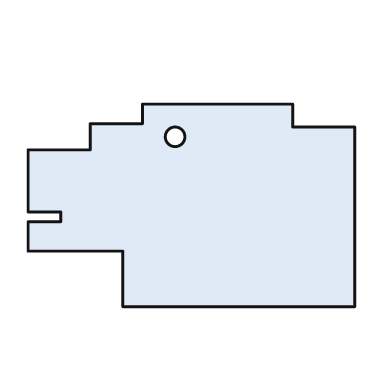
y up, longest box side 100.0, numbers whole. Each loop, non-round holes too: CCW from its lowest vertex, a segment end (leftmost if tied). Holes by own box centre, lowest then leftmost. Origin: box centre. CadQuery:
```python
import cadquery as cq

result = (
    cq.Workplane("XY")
    .moveTo(-21.0, -31.0)
    .lineTo(50.0, -31.0)
    .lineTo(50.0, 24.0)
    .lineTo(31.0, 24.0)
    .lineTo(31.0, 31.0)
    .lineTo(-15.0, 31.0)
    .lineTo(-15.0, 25.0)
    .lineTo(-31.0, 25.0)
    .lineTo(-31.0, 17.0)
    .lineTo(-50.0, 17.0)
    .lineTo(-50.0, -2.0)
    .lineTo(-40.0, -2.0)
    .lineTo(-40.0, -5.0)
    .lineTo(-50.0, -5.0)
    .lineTo(-50.0, -14.0)
    .lineTo(-21.0, -14.0)
    .close()
    .moveTo(-5.0, 21.0)
    .circle(3.0)
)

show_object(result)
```